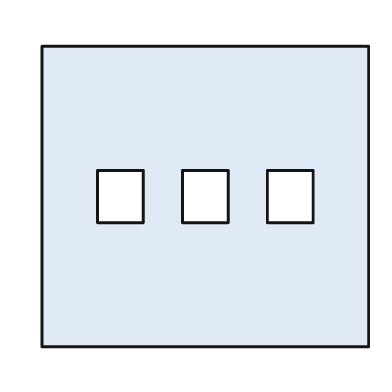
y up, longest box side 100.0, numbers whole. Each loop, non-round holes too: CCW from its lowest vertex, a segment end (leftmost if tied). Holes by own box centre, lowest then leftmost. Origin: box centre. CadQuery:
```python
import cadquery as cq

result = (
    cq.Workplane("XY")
    .moveTo(-50.0, -46.0)
    .lineTo(50.0, -46.0)
    .lineTo(50.0, 46.0)
    .lineTo(-50.0, 46.0)
    .close()
    .moveTo(-33.0, -8.0)
    .lineTo(-19.0, -8.0)
    .lineTo(-19.0, 8.0)
    .lineTo(-33.0, 8.0)
    .close()
    .moveTo(-7.0, -8.0)
    .lineTo(7.0, -8.0)
    .lineTo(7.0, 8.0)
    .lineTo(-7.0, 8.0)
    .close()
    .moveTo(19.0, -8.0)
    .lineTo(33.0, -8.0)
    .lineTo(33.0, 8.0)
    .lineTo(19.0, 8.0)
    .close()
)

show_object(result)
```